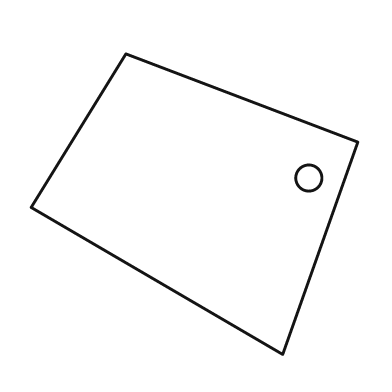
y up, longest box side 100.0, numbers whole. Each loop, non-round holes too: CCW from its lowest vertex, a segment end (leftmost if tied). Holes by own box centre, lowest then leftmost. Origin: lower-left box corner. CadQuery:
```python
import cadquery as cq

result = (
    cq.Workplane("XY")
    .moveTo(77.0, 0.0)
    .lineTo(100.0, 65.0)
    .lineTo(29.0, 92.0)
    .lineTo(0.0, 45.0)
    .close()
    .moveTo(85.0, 54.0)
    .circle(4.0)
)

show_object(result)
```